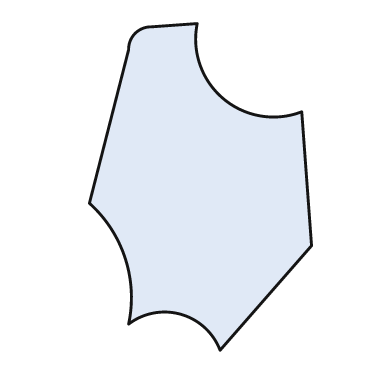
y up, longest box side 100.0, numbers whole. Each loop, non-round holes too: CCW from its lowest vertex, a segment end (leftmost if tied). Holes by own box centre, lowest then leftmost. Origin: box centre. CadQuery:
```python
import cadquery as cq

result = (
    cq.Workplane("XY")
    .moveTo(6.0, -50.0)
    .lineTo(34.0, -18.0)
    .lineTo(31.0, 23.0)
    .threePointArc((7.0, 27.0), (-1.0, 50.0))
    .lineTo(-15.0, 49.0)
    .threePointArc((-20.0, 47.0), (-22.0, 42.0))
    .lineTo(-34.0, -5.0)
    .threePointArc((-23.0, -22.0), (-22.0, -42.0))
    .threePointArc((-6.0, -39.0), (6.0, -50.0))
    .close()
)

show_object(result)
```